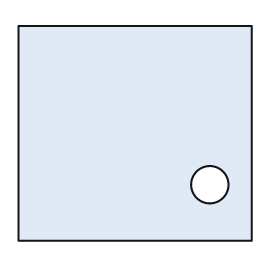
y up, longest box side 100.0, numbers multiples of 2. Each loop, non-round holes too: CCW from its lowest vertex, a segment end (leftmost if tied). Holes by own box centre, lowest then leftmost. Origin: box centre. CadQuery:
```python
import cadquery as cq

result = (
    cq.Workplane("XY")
    .moveTo(-50.0, -46.0)
    .lineTo(50.0, -46.0)
    .lineTo(50.0, 46.0)
    .lineTo(-50.0, 46.0)
    .close()
    .moveTo(32.0, -22.0)
    .circle(8.0)
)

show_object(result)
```